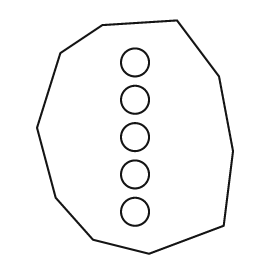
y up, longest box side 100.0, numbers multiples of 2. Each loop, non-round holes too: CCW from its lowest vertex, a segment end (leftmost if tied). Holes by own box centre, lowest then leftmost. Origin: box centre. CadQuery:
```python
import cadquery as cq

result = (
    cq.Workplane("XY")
    .moveTo(6.0, -50.0)
    .lineTo(38.0, -38.0)
    .lineTo(42.0, -6.0)
    .lineTo(36.0, 26.0)
    .lineTo(18.0, 50.0)
    .lineTo(-14.0, 48.0)
    .lineTo(-32.0, 36.0)
    .lineTo(-42.0, 4.0)
    .lineTo(-34.0, -26.0)
    .lineTo(-18.0, -44.0)
    .close()
    .moveTo(0.0, -32.0)
    .circle(6.0)
    .moveTo(0.0, -16.0)
    .circle(6.0)
    .moveTo(0.0, 0.0)
    .circle(6.0)
    .moveTo(0.0, 16.0)
    .circle(6.0)
    .moveTo(0.0, 32.0)
    .circle(6.0)
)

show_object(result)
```